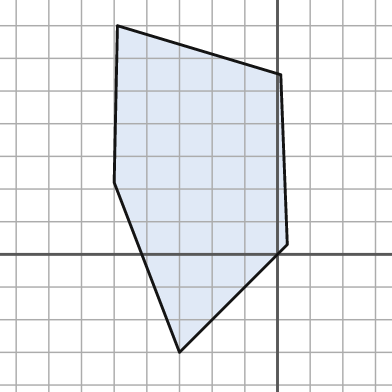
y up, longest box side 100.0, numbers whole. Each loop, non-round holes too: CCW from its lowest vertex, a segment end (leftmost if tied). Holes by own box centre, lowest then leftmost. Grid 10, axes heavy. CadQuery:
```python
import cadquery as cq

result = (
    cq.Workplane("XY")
    .moveTo(-30.0, -30.0)
    .lineTo(3.0, 3.0)
    .lineTo(1.0, 55.0)
    .lineTo(-49.0, 70.0)
    .lineTo(-50.0, 22.0)
    .close()
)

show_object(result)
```